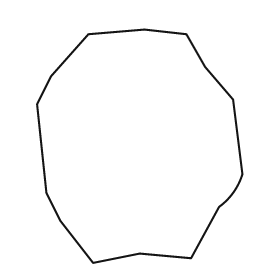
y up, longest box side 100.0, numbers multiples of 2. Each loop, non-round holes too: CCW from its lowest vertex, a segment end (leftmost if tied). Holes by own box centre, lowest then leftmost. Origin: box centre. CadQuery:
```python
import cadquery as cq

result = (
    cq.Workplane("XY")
    .moveTo(-20.0, -50.0)
    .lineTo(0.0, -46.0)
    .lineTo(22.0, -48.0)
    .lineTo(34.0, -26.0)
    .threePointArc((40.0, -20.0), (44.0, -12.0))
    .lineTo(40.0, 20.0)
    .lineTo(28.0, 34.0)
    .lineTo(20.0, 48.0)
    .lineTo(2.0, 50.0)
    .lineTo(-22.0, 48.0)
    .lineTo(-38.0, 30.0)
    .lineTo(-44.0, 18.0)
    .lineTo(-40.0, -20.0)
    .lineTo(-34.0, -32.0)
    .close()
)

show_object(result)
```